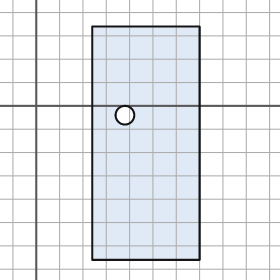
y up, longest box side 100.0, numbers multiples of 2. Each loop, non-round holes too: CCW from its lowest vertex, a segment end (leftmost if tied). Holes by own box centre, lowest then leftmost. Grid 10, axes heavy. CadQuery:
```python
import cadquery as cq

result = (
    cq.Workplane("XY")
    .moveTo(24.0, -66.0)
    .lineTo(70.0, -66.0)
    .lineTo(70.0, 34.0)
    .lineTo(24.0, 34.0)
    .close()
    .moveTo(38.0, -4.0)
    .circle(4.0)
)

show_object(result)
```